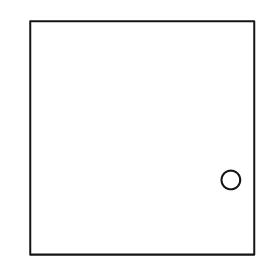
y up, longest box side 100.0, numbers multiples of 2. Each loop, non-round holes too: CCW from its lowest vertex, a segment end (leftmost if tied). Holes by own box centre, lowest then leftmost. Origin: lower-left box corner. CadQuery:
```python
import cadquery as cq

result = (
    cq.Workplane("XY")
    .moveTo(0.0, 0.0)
    .lineTo(96.0, 0.0)
    .lineTo(96.0, 100.0)
    .lineTo(0.0, 100.0)
    .close()
    .moveTo(86.0, 32.0)
    .circle(4.0)
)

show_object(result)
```